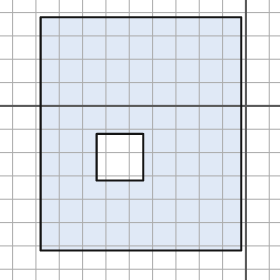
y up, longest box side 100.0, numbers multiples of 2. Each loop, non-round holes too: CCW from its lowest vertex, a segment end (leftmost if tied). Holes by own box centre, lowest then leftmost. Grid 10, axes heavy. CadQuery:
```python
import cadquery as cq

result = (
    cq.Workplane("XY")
    .moveTo(-88.0, -62.0)
    .lineTo(-2.0, -62.0)
    .lineTo(-2.0, 38.0)
    .lineTo(-88.0, 38.0)
    .close()
    .moveTo(-64.0, -32.0)
    .lineTo(-44.0, -32.0)
    .lineTo(-44.0, -12.0)
    .lineTo(-64.0, -12.0)
    .close()
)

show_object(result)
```